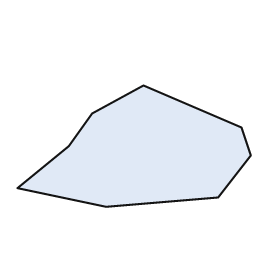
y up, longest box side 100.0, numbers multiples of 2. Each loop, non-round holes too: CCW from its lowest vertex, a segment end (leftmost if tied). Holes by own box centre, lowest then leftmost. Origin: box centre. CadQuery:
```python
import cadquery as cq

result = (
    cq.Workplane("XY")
    .moveTo(-12.0, -26.0)
    .lineTo(36.0, -22.0)
    .lineTo(50.0, -4.0)
    .lineTo(46.0, 8.0)
    .lineTo(4.0, 26.0)
    .lineTo(-18.0, 14.0)
    .lineTo(-28.0, 0.0)
    .lineTo(-50.0, -18.0)
    .close()
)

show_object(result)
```